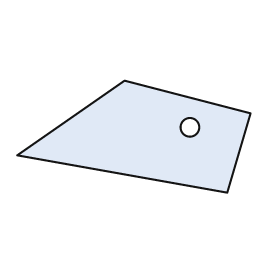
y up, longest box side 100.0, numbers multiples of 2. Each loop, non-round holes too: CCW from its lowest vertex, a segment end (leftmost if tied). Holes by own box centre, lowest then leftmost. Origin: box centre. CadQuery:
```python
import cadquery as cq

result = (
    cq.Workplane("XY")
    .moveTo(40.0, -24.0)
    .lineTo(50.0, 10.0)
    .lineTo(-4.0, 24.0)
    .lineTo(-50.0, -8.0)
    .close()
    .moveTo(24.0, 4.0)
    .circle(4.0)
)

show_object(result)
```